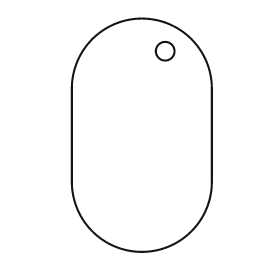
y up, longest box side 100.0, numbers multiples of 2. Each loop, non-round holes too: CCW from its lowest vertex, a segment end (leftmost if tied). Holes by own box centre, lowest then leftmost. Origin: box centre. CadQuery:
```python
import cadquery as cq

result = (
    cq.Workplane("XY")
    .moveTo(-30.0, -20.0)
    .threePointArc((0.0, -50.0), (30.0, -20.0))
    .lineTo(30.0, 20.0)
    .threePointArc((0.0, 50.0), (-30.0, 20.0))
    .close()
    .moveTo(10.0, 36.0)
    .circle(4.0)
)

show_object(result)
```